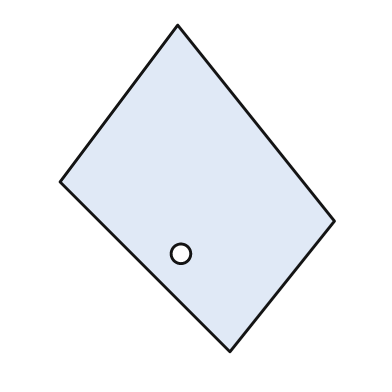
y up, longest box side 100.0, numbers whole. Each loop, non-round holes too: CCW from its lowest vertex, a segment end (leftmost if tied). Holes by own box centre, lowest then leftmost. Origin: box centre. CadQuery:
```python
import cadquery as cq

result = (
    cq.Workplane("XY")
    .moveTo(10.0, -50.0)
    .lineTo(42.0, -10.0)
    .lineTo(-6.0, 50.0)
    .lineTo(-42.0, 2.0)
    .close()
    .moveTo(-5.0, -20.0)
    .circle(3.0)
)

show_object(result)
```